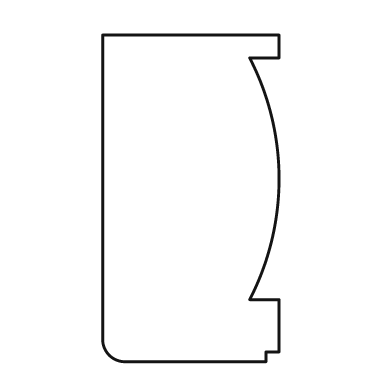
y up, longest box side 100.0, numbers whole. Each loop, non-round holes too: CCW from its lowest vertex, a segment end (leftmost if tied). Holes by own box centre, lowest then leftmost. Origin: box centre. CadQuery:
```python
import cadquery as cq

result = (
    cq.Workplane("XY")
    .moveTo(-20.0, -50.0)
    .lineTo(23.0, -50.0)
    .lineTo(23.0, -47.0)
    .lineTo(27.0, -47.0)
    .lineTo(27.0, -31.0)
    .lineTo(18.0, -31.0)
    .threePointArc((27.0, 6.0), (18.0, 43.0))
    .lineTo(27.0, 43.0)
    .lineTo(27.0, 50.0)
    .lineTo(-27.0, 50.0)
    .lineTo(-27.0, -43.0)
    .threePointArc((-25.0, -48.0), (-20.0, -50.0))
    .close()
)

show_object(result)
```